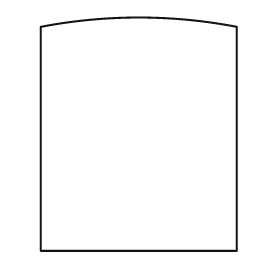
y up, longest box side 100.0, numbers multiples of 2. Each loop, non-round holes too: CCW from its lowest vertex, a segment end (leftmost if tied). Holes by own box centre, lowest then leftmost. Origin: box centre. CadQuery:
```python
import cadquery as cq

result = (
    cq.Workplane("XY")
    .moveTo(-42.0, -50.0)
    .lineTo(42.0, -50.0)
    .lineTo(42.0, 46.0)
    .threePointArc((0.0, 50.0), (-42.0, 46.0))
    .close()
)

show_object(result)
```